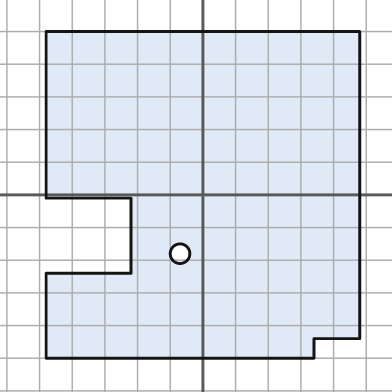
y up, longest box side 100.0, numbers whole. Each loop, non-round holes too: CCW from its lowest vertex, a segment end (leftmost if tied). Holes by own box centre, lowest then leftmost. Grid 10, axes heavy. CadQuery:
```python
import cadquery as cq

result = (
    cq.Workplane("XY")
    .moveTo(-48.0, -50.0)
    .lineTo(34.0, -50.0)
    .lineTo(34.0, -44.0)
    .lineTo(48.0, -44.0)
    .lineTo(48.0, 50.0)
    .lineTo(-48.0, 50.0)
    .lineTo(-48.0, -1.0)
    .lineTo(-22.0, -1.0)
    .lineTo(-22.0, -24.0)
    .lineTo(-48.0, -24.0)
    .close()
    .moveTo(-7.0, -18.0)
    .circle(3.0)
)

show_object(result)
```